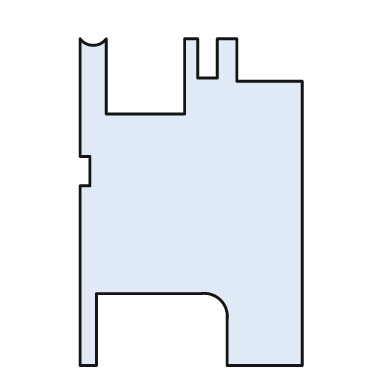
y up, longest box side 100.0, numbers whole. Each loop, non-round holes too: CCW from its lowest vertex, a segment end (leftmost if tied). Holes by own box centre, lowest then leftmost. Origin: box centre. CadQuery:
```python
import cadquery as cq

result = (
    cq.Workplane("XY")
    .moveTo(-34.0, -50.0)
    .lineTo(-29.0, -50.0)
    .lineTo(-29.0, -28.0)
    .lineTo(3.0, -28.0)
    .threePointArc((9.0, -30.0), (11.0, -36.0))
    .lineTo(11.0, -50.0)
    .lineTo(34.0, -50.0)
    .lineTo(34.0, 37.0)
    .lineTo(14.0, 37.0)
    .lineTo(14.0, 50.0)
    .lineTo(8.0, 50.0)
    .lineTo(8.0, 38.0)
    .lineTo(2.0, 38.0)
    .lineTo(2.0, 50.0)
    .lineTo(-2.0, 50.0)
    .lineTo(-2.0, 27.0)
    .lineTo(-26.0, 27.0)
    .lineTo(-26.0, 50.0)
    .threePointArc((-30.0, 48.0), (-34.0, 50.0))
    .lineTo(-34.0, 14.0)
    .lineTo(-31.0, 14.0)
    .lineTo(-31.0, 5.0)
    .lineTo(-34.0, 5.0)
    .close()
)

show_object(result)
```